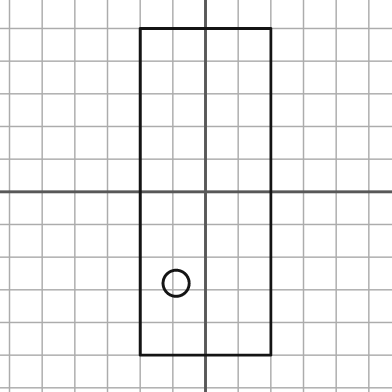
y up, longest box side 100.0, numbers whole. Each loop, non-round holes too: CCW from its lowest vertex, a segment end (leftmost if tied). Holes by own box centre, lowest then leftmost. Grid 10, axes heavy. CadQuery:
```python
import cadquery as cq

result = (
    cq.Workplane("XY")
    .moveTo(-20.0, -50.0)
    .lineTo(20.0, -50.0)
    .lineTo(20.0, 50.0)
    .lineTo(-20.0, 50.0)
    .close()
    .moveTo(-9.0, -28.0)
    .circle(4.0)
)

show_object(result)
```